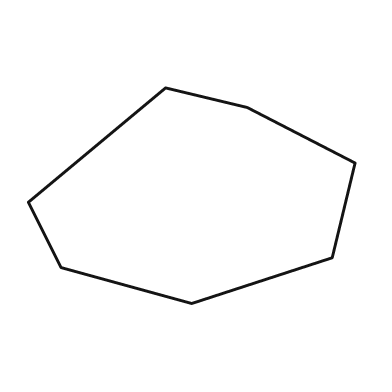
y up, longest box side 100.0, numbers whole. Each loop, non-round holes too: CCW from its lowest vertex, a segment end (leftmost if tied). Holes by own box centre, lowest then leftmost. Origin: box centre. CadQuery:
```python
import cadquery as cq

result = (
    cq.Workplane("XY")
    .moveTo(0.0, -33.0)
    .lineTo(43.0, -19.0)
    .lineTo(50.0, 10.0)
    .lineTo(17.0, 27.0)
    .lineTo(-8.0, 33.0)
    .lineTo(-50.0, -2.0)
    .lineTo(-40.0, -22.0)
    .close()
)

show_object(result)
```